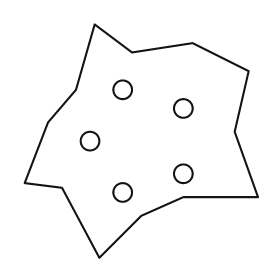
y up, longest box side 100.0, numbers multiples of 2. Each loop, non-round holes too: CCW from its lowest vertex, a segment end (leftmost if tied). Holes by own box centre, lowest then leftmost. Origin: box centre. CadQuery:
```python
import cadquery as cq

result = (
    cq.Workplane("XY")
    .moveTo(-18.0, -50.0)
    .lineTo(0.0, -32.0)
    .lineTo(18.0, -24.0)
    .lineTo(50.0, -24.0)
    .lineTo(40.0, 4.0)
    .lineTo(46.0, 30.0)
    .lineTo(22.0, 42.0)
    .lineTo(-4.0, 38.0)
    .lineTo(-20.0, 50.0)
    .lineTo(-28.0, 22.0)
    .lineTo(-40.0, 8.0)
    .lineTo(-50.0, -18.0)
    .lineTo(-34.0, -20.0)
    .close()
    .moveTo(-8.0, -22.0)
    .circle(4.0)
    .moveTo(18.0, -14.0)
    .circle(4.0)
    .moveTo(-22.0, 0.0)
    .circle(4.0)
    .moveTo(18.0, 14.0)
    .circle(4.0)
    .moveTo(-8.0, 22.0)
    .circle(4.0)
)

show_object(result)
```